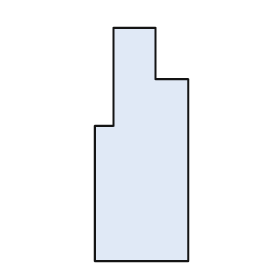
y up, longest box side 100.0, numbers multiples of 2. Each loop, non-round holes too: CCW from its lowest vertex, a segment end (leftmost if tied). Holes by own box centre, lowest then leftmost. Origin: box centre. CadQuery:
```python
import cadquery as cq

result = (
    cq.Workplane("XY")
    .moveTo(-20.0, -50.0)
    .lineTo(20.0, -50.0)
    .lineTo(20.0, 28.0)
    .lineTo(6.0, 28.0)
    .lineTo(6.0, 50.0)
    .lineTo(-12.0, 50.0)
    .lineTo(-12.0, 8.0)
    .lineTo(-20.0, 8.0)
    .close()
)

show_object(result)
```